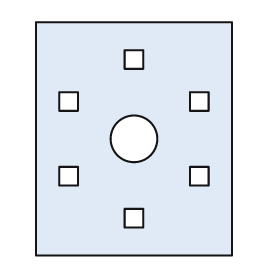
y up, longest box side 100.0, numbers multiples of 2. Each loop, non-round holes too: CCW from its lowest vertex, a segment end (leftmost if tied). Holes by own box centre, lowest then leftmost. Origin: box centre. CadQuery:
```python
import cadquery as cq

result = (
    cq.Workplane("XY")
    .moveTo(-42.0, -50.0)
    .lineTo(42.0, -50.0)
    .lineTo(42.0, 50.0)
    .lineTo(-42.0, 50.0)
    .close()
    .moveTo(-4.0, -38.0)
    .lineTo(4.0, -38.0)
    .lineTo(4.0, -30.0)
    .lineTo(-4.0, -30.0)
    .close()
    .moveTo(-32.0, -20.0)
    .lineTo(-24.0, -20.0)
    .lineTo(-24.0, -12.0)
    .lineTo(-32.0, -12.0)
    .close()
    .moveTo(24.0, -20.0)
    .lineTo(32.0, -20.0)
    .lineTo(32.0, -12.0)
    .lineTo(24.0, -12.0)
    .close()
    .moveTo(0.0, 0.0)
    .circle(10.0)
    .moveTo(-32.0, 12.0)
    .lineTo(-24.0, 12.0)
    .lineTo(-24.0, 20.0)
    .lineTo(-32.0, 20.0)
    .close()
    .moveTo(24.0, 12.0)
    .lineTo(32.0, 12.0)
    .lineTo(32.0, 20.0)
    .lineTo(24.0, 20.0)
    .close()
    .moveTo(-4.0, 30.0)
    .lineTo(4.0, 30.0)
    .lineTo(4.0, 38.0)
    .lineTo(-4.0, 38.0)
    .close()
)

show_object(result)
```